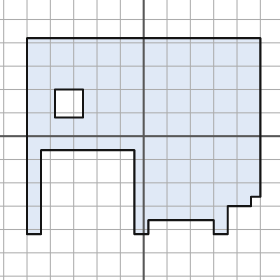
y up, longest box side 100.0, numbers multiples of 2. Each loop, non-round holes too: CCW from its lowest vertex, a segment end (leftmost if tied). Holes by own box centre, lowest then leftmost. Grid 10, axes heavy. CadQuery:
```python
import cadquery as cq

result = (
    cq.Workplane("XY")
    .moveTo(-50.0, -42.0)
    .lineTo(-44.0, -42.0)
    .lineTo(-44.0, -6.0)
    .lineTo(-4.0, -6.0)
    .lineTo(-4.0, -42.0)
    .lineTo(2.0, -42.0)
    .lineTo(2.0, -36.0)
    .lineTo(30.0, -36.0)
    .lineTo(30.0, -42.0)
    .lineTo(36.0, -42.0)
    .lineTo(36.0, -30.0)
    .lineTo(46.0, -30.0)
    .lineTo(46.0, -26.0)
    .lineTo(50.0, -26.0)
    .lineTo(50.0, 42.0)
    .lineTo(-50.0, 42.0)
    .close()
    .moveTo(-38.0, 8.0)
    .lineTo(-26.0, 8.0)
    .lineTo(-26.0, 20.0)
    .lineTo(-38.0, 20.0)
    .close()
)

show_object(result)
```